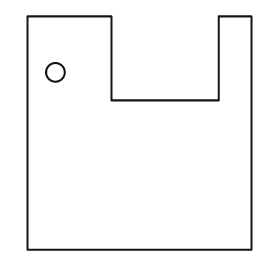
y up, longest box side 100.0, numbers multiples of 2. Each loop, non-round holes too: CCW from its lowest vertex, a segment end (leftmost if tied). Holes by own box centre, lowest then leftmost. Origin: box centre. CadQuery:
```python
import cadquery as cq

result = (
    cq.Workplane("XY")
    .moveTo(-48.0, -50.0)
    .lineTo(48.0, -50.0)
    .lineTo(48.0, 50.0)
    .lineTo(34.0, 50.0)
    .lineTo(34.0, 14.0)
    .lineTo(-12.0, 14.0)
    .lineTo(-12.0, 50.0)
    .lineTo(-48.0, 50.0)
    .close()
    .moveTo(-36.0, 26.0)
    .circle(4.0)
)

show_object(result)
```